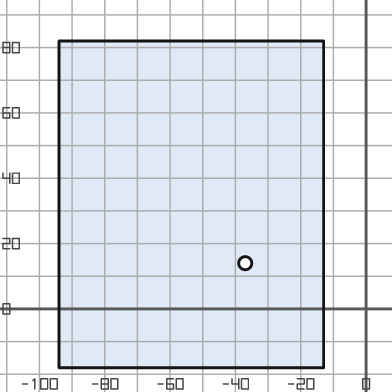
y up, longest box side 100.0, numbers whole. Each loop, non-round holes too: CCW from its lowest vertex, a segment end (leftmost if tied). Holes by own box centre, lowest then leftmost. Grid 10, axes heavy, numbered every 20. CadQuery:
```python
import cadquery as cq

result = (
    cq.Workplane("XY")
    .moveTo(-94.0, -18.0)
    .lineTo(-13.0, -18.0)
    .lineTo(-13.0, 82.0)
    .lineTo(-94.0, 82.0)
    .close()
    .moveTo(-37.0, 14.0)
    .circle(2.0)
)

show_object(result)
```